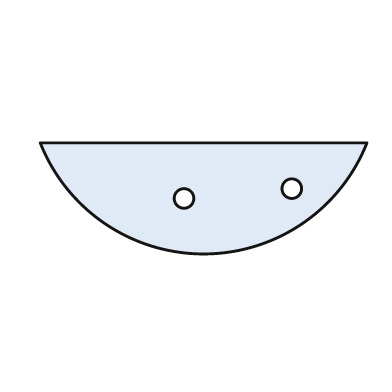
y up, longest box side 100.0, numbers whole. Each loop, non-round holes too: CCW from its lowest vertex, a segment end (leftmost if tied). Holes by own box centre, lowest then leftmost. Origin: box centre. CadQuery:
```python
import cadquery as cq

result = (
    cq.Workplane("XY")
    .moveTo(-50.0, 17.0)
    .threePointArc((0.0, -17.0), (50.0, 17.0))
    .close()
    .moveTo(-6.0, 0.0)
    .circle(3.0)
    .moveTo(27.0, 3.0)
    .circle(3.0)
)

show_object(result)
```